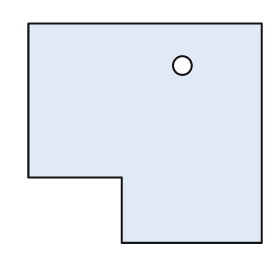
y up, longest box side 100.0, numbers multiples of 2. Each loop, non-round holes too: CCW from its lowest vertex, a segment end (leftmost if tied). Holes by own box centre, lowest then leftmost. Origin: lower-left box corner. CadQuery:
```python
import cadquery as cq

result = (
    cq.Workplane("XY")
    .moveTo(40.0, 0.0)
    .lineTo(100.0, 0.0)
    .lineTo(100.0, 94.0)
    .lineTo(0.0, 94.0)
    .lineTo(0.0, 28.0)
    .lineTo(40.0, 28.0)
    .close()
    .moveTo(66.0, 76.0)
    .circle(4.0)
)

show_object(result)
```